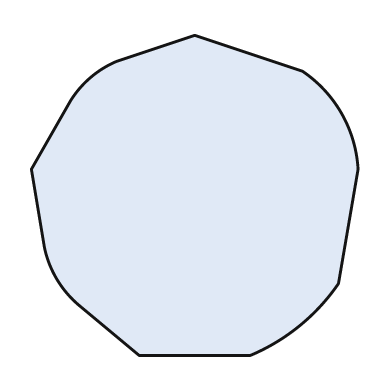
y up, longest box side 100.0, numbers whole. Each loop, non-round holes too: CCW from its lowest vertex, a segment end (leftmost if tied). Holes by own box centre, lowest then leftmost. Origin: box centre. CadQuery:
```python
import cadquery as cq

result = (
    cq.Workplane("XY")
    .moveTo(-17.0, -49.0)
    .lineTo(17.0, -49.0)
    .threePointArc((32.0, -40.0), (44.0, -27.0))
    .lineTo(50.0, 8.0)
    .threePointArc((45.0, 25.0), (33.0, 38.0))
    .lineTo(0.0, 49.0)
    .lineTo(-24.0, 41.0)
    .threePointArc((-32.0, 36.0), (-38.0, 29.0))
    .lineTo(-50.0, 8.0)
    .lineTo(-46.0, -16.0)
    .threePointArc((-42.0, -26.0), (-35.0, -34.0))
    .close()
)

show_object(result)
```